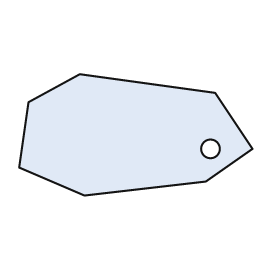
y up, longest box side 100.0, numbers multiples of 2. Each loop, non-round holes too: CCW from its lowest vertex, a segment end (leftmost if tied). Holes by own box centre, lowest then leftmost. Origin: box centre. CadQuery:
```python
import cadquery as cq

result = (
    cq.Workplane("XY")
    .moveTo(-22.0, -26.0)
    .lineTo(30.0, -20.0)
    .lineTo(50.0, -6.0)
    .lineTo(34.0, 18.0)
    .lineTo(-24.0, 26.0)
    .lineTo(-46.0, 14.0)
    .lineTo(-50.0, -14.0)
    .close()
    .moveTo(32.0, -6.0)
    .circle(4.0)
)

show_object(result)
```